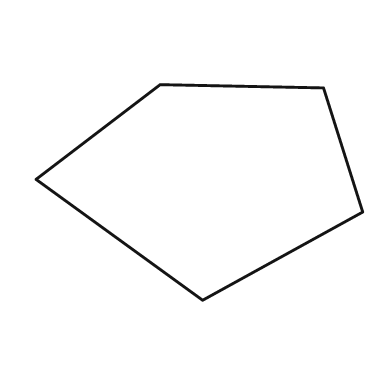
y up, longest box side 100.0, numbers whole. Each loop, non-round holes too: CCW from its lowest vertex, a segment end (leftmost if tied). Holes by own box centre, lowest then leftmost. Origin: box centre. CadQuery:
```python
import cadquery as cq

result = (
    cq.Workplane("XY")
    .moveTo(1.0, -33.0)
    .lineTo(50.0, -6.0)
    .lineTo(38.0, 32.0)
    .lineTo(-12.0, 33.0)
    .lineTo(-50.0, 4.0)
    .close()
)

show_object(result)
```